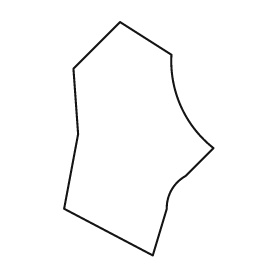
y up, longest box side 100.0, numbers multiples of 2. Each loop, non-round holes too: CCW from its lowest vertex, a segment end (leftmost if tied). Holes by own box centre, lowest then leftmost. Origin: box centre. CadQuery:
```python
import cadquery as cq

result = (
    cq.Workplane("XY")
    .moveTo(6.0, -50.0)
    .lineTo(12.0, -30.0)
    .threePointArc((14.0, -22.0), (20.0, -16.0))
    .lineTo(32.0, -4.0)
    .threePointArc((18.0, 14.0), (14.0, 36.0))
    .lineTo(-8.0, 50.0)
    .lineTo(-28.0, 30.0)
    .lineTo(-26.0, 2.0)
    .lineTo(-32.0, -30.0)
    .close()
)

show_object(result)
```